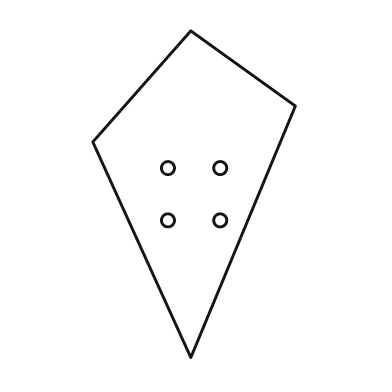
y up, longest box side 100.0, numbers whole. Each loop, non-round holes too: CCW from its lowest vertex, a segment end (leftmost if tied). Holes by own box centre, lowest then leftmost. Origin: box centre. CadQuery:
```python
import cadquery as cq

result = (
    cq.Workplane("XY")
    .moveTo(-1.0, -50.0)
    .lineTo(31.0, 27.0)
    .lineTo(-1.0, 50.0)
    .lineTo(-31.0, 16.0)
    .close()
    .moveTo(-8.0, -8.0)
    .circle(2.0)
    .moveTo(8.0, -8.0)
    .circle(2.0)
    .moveTo(-8.0, 8.0)
    .circle(2.0)
    .moveTo(8.0, 8.0)
    .circle(2.0)
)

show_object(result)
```